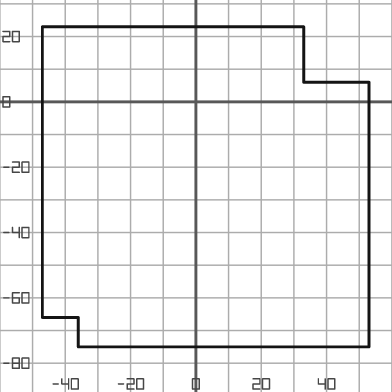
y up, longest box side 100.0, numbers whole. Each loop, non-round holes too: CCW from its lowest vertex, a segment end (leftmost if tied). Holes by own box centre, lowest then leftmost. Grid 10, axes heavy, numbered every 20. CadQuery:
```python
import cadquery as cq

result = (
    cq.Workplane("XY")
    .moveTo(-36.0, -75.0)
    .lineTo(53.0, -75.0)
    .lineTo(53.0, 6.0)
    .lineTo(33.0, 6.0)
    .lineTo(33.0, 23.0)
    .lineTo(-47.0, 23.0)
    .lineTo(-47.0, -66.0)
    .lineTo(-36.0, -66.0)
    .close()
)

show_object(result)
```